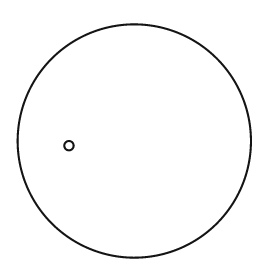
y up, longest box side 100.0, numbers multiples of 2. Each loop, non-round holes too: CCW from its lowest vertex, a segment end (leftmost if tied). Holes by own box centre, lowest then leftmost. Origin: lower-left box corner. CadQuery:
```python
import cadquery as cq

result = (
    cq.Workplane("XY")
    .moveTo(50.0, 50.0)
    .circle(50.0)
    .moveTo(22.0, 48.0)
    .circle(2.0)
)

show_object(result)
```